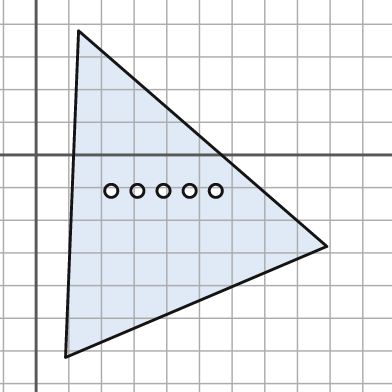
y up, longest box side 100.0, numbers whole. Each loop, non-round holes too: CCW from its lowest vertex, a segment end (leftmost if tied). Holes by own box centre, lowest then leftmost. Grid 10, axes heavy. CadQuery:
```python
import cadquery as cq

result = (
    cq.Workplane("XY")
    .moveTo(9.0, -62.0)
    .lineTo(89.0, -28.0)
    .lineTo(13.0, 38.0)
    .close()
    .moveTo(23.0, -11.0)
    .circle(2.0)
    .moveTo(31.0, -11.0)
    .circle(2.0)
    .moveTo(39.0, -11.0)
    .circle(2.0)
    .moveTo(47.0, -11.0)
    .circle(2.0)
    .moveTo(55.0, -11.0)
    .circle(2.0)
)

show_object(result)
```